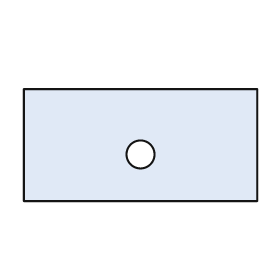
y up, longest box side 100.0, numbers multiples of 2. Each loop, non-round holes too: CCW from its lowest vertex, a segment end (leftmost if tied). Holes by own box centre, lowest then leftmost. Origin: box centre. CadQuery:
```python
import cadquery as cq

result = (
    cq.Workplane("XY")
    .moveTo(-50.0, -24.0)
    .lineTo(50.0, -24.0)
    .lineTo(50.0, 24.0)
    .lineTo(-50.0, 24.0)
    .close()
    .moveTo(0.0, -4.0)
    .circle(6.0)
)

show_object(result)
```